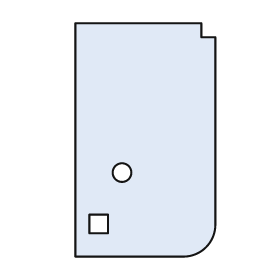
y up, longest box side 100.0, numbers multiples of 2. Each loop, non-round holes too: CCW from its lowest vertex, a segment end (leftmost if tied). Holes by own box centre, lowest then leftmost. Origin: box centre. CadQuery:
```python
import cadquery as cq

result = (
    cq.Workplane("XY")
    .moveTo(-30.0, -50.0)
    .lineTo(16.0, -50.0)
    .threePointArc((26.0, -46.0), (30.0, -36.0))
    .lineTo(30.0, 44.0)
    .lineTo(24.0, 44.0)
    .lineTo(24.0, 50.0)
    .lineTo(-30.0, 50.0)
    .close()
    .moveTo(-24.0, -40.0)
    .lineTo(-16.0, -40.0)
    .lineTo(-16.0, -32.0)
    .lineTo(-24.0, -32.0)
    .close()
    .moveTo(-10.0, -14.0)
    .circle(4.0)
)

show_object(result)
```